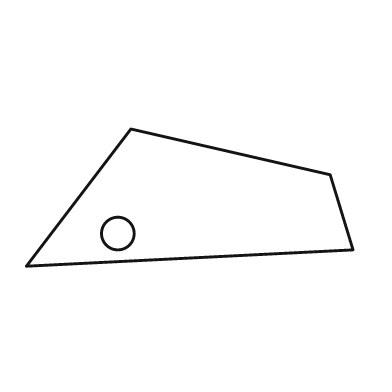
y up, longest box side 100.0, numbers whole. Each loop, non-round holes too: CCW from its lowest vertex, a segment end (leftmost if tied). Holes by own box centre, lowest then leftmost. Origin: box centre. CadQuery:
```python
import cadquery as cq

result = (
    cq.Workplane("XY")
    .moveTo(-50.0, -21.0)
    .lineTo(50.0, -16.0)
    .lineTo(43.0, 7.0)
    .lineTo(-18.0, 21.0)
    .close()
    .moveTo(-22.0, -11.0)
    .circle(5.0)
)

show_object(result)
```